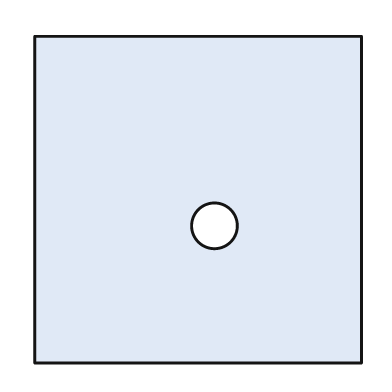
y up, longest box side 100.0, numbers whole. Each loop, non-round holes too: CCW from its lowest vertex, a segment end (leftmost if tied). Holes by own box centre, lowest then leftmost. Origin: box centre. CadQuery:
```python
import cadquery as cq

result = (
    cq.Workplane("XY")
    .moveTo(-50.0, -50.0)
    .lineTo(50.0, -50.0)
    .lineTo(50.0, 50.0)
    .lineTo(-50.0, 50.0)
    .close()
    .moveTo(5.0, -8.0)
    .circle(7.0)
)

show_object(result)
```